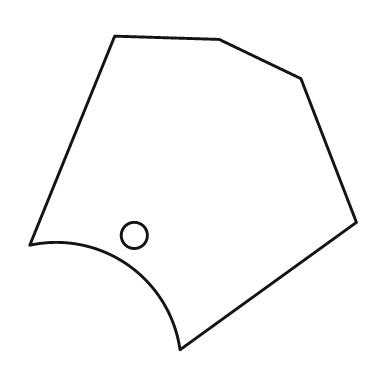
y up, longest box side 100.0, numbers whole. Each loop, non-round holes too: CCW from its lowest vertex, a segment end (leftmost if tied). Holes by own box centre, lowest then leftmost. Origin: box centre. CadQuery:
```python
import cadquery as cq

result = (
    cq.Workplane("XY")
    .moveTo(-4.0, -48.0)
    .lineTo(50.0, -9.0)
    .lineTo(33.0, 35.0)
    .lineTo(8.0, 47.0)
    .lineTo(-24.0, 48.0)
    .lineTo(-50.0, -16.0)
    .threePointArc((-20.0, -22.0), (-4.0, -48.0))
    .close()
    .moveTo(-18.0, -13.0)
    .circle(4.0)
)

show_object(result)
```